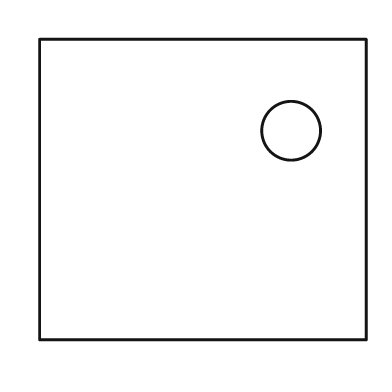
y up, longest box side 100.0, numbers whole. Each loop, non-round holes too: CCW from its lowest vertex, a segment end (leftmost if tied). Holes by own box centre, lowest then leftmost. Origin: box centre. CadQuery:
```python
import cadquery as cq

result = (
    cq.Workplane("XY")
    .moveTo(-50.0, -46.0)
    .lineTo(50.0, -46.0)
    .lineTo(50.0, 46.0)
    .lineTo(-50.0, 46.0)
    .close()
    .moveTo(27.0, 18.0)
    .circle(9.0)
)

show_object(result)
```